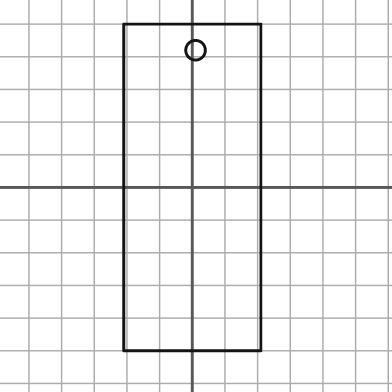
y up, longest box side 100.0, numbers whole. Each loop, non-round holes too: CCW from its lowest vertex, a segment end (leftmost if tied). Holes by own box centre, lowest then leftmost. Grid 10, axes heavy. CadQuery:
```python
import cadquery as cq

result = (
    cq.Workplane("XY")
    .moveTo(-21.0, -50.0)
    .lineTo(21.0, -50.0)
    .lineTo(21.0, 50.0)
    .lineTo(-21.0, 50.0)
    .close()
    .moveTo(1.0, 42.0)
    .circle(3.0)
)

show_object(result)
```